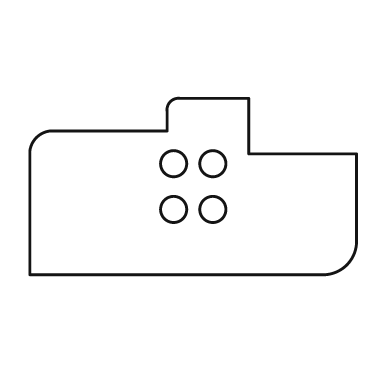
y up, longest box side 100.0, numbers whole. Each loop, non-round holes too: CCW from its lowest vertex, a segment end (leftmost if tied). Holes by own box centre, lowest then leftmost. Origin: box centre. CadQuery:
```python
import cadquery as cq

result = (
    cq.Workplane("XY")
    .moveTo(-50.0, -27.0)
    .lineTo(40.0, -27.0)
    .threePointArc((47.0, -24.0), (50.0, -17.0))
    .lineTo(50.0, 10.0)
    .lineTo(17.0, 10.0)
    .lineTo(17.0, 27.0)
    .lineTo(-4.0, 27.0)
    .threePointArc((-7.0, 26.0), (-8.0, 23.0))
    .lineTo(-8.0, 17.0)
    .lineTo(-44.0, 17.0)
    .threePointArc((-48.0, 15.0), (-50.0, 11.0))
    .close()
    .moveTo(-6.0, -7.0)
    .circle(4.0)
    .moveTo(6.0, -7.0)
    .circle(4.0)
    .moveTo(-6.0, 7.0)
    .circle(4.0)
    .moveTo(6.0, 7.0)
    .circle(4.0)
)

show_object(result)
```